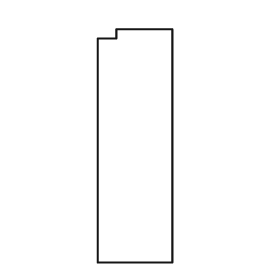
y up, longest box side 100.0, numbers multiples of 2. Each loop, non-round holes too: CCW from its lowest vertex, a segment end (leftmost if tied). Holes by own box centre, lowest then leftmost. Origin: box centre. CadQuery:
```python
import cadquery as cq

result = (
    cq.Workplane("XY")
    .moveTo(-16.0, -50.0)
    .lineTo(16.0, -50.0)
    .lineTo(16.0, 50.0)
    .lineTo(-8.0, 50.0)
    .lineTo(-8.0, 46.0)
    .lineTo(-16.0, 46.0)
    .close()
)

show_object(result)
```